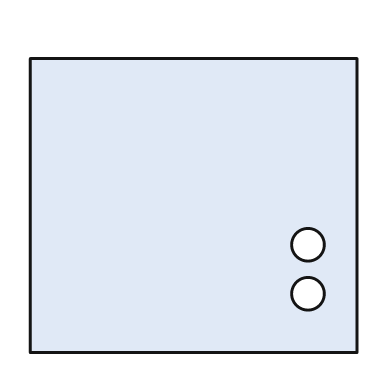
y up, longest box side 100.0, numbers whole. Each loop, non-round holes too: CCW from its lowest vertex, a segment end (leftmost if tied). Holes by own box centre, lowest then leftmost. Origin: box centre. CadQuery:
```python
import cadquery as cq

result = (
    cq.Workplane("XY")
    .moveTo(-50.0, -45.0)
    .lineTo(50.0, -45.0)
    .lineTo(50.0, 45.0)
    .lineTo(-50.0, 45.0)
    .close()
    .moveTo(35.0, -27.0)
    .circle(5.0)
    .moveTo(35.0, -12.0)
    .circle(5.0)
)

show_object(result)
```